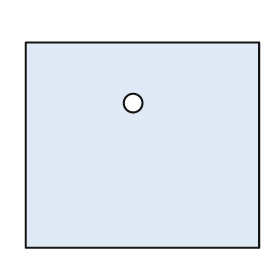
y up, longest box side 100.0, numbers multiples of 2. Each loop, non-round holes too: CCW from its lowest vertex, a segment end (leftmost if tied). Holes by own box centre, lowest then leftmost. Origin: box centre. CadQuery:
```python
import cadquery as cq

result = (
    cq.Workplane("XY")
    .moveTo(-50.0, -44.0)
    .lineTo(50.0, -44.0)
    .lineTo(50.0, 44.0)
    .lineTo(-50.0, 44.0)
    .close()
    .moveTo(-4.0, 18.0)
    .circle(4.0)
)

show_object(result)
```